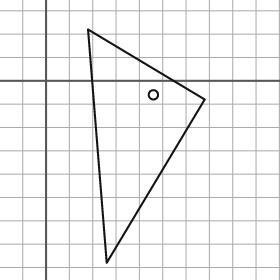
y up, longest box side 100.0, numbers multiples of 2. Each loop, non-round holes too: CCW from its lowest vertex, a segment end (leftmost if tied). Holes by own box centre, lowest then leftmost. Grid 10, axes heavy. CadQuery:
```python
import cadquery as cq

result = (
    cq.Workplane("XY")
    .moveTo(26.0, -78.0)
    .lineTo(68.0, -8.0)
    .lineTo(18.0, 22.0)
    .close()
    .moveTo(46.0, -6.0)
    .circle(2.0)
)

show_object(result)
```